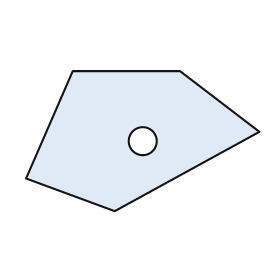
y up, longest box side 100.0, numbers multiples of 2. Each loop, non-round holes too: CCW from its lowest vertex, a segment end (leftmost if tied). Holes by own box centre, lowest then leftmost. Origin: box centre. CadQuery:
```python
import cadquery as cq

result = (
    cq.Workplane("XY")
    .moveTo(-12.0, -30.0)
    .lineTo(50.0, 4.0)
    .lineTo(16.0, 30.0)
    .lineTo(-30.0, 30.0)
    .lineTo(-50.0, -16.0)
    .close()
    .moveTo(0.0, 0.0)
    .circle(6.0)
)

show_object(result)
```